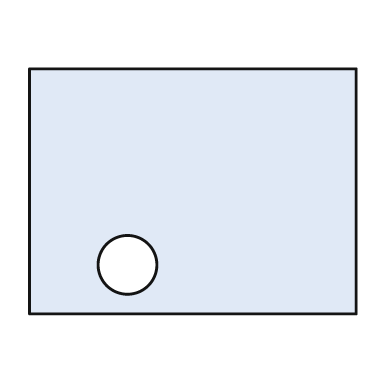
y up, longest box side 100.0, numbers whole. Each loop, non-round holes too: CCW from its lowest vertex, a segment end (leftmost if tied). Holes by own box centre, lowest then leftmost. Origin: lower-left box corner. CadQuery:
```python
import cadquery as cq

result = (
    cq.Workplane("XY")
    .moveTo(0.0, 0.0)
    .lineTo(100.0, 0.0)
    .lineTo(100.0, 75.0)
    .lineTo(0.0, 75.0)
    .close()
    .moveTo(30.0, 15.0)
    .circle(9.0)
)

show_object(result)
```